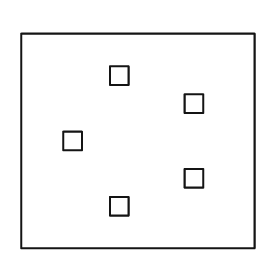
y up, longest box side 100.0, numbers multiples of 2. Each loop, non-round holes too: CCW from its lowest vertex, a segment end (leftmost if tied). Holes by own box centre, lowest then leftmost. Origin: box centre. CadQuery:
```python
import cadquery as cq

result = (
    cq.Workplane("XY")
    .moveTo(-50.0, -46.0)
    .lineTo(50.0, -46.0)
    .lineTo(50.0, 46.0)
    .lineTo(-50.0, 46.0)
    .close()
    .moveTo(-12.0, -32.0)
    .lineTo(-4.0, -32.0)
    .lineTo(-4.0, -24.0)
    .lineTo(-12.0, -24.0)
    .close()
    .moveTo(20.0, -20.0)
    .lineTo(28.0, -20.0)
    .lineTo(28.0, -12.0)
    .lineTo(20.0, -12.0)
    .close()
    .moveTo(-32.0, -4.0)
    .lineTo(-24.0, -4.0)
    .lineTo(-24.0, 4.0)
    .lineTo(-32.0, 4.0)
    .close()
    .moveTo(20.0, 12.0)
    .lineTo(28.0, 12.0)
    .lineTo(28.0, 20.0)
    .lineTo(20.0, 20.0)
    .close()
    .moveTo(-12.0, 24.0)
    .lineTo(-4.0, 24.0)
    .lineTo(-4.0, 32.0)
    .lineTo(-12.0, 32.0)
    .close()
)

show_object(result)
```